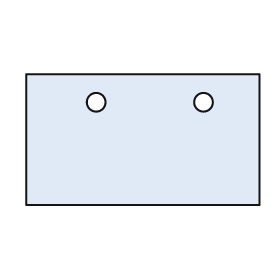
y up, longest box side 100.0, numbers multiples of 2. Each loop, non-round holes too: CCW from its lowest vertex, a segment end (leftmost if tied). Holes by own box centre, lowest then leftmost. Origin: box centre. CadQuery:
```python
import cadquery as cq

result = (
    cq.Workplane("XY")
    .moveTo(-50.0, -28.0)
    .lineTo(50.0, -28.0)
    .lineTo(50.0, 28.0)
    .lineTo(-50.0, 28.0)
    .close()
    .moveTo(-20.0, 16.0)
    .circle(4.0)
    .moveTo(26.0, 16.0)
    .circle(4.0)
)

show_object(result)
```